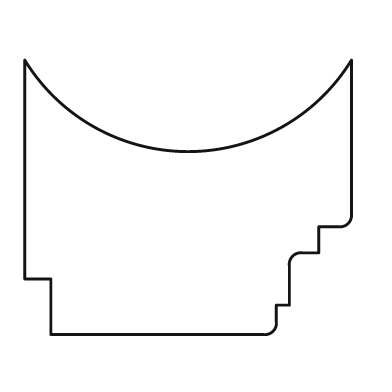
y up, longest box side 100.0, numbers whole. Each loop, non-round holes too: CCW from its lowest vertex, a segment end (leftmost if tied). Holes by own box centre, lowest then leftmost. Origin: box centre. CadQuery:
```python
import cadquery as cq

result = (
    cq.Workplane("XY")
    .moveTo(-42.0, -42.0)
    .lineTo(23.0, -42.0)
    .threePointArc((26.0, -41.0), (27.0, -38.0))
    .lineTo(27.0, -33.0)
    .lineTo(31.0, -33.0)
    .lineTo(31.0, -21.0)
    .threePointArc((32.0, -18.0), (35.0, -17.0))
    .lineTo(40.0, -17.0)
    .lineTo(40.0, -9.0)
    .lineTo(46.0, -9.0)
    .threePointArc((49.0, -8.0), (50.0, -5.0))
    .lineTo(50.0, 42.0)
    .threePointArc((0.0, 14.0), (-50.0, 42.0))
    .lineTo(-50.0, -25.0)
    .lineTo(-42.0, -25.0)
    .close()
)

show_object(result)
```